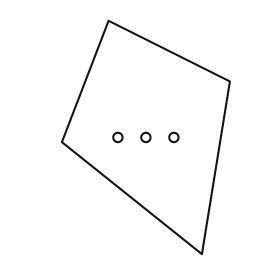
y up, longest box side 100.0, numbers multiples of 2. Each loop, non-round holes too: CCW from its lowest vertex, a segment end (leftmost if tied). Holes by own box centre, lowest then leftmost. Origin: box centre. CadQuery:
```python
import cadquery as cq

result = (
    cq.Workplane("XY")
    .moveTo(24.0, -50.0)
    .lineTo(36.0, 24.0)
    .lineTo(-16.0, 50.0)
    .lineTo(-36.0, -2.0)
    .close()
    .moveTo(-12.0, 0.0)
    .circle(2.0)
    .moveTo(0.0, 0.0)
    .circle(2.0)
    .moveTo(12.0, 0.0)
    .circle(2.0)
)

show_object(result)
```